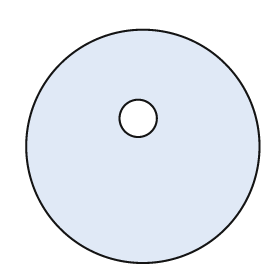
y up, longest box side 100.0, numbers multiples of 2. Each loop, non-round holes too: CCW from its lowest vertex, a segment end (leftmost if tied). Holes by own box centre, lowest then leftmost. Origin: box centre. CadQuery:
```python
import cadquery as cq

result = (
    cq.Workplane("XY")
    .moveTo(0.0, 0.0)
    .circle(50.0)
    .moveTo(-2.0, 12.0)
    .circle(8.0)
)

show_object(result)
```